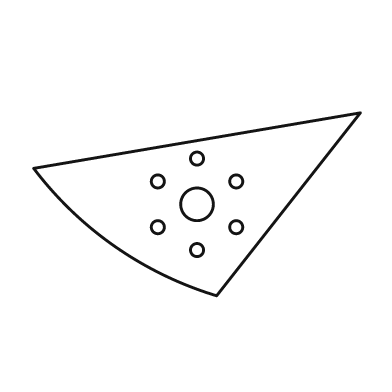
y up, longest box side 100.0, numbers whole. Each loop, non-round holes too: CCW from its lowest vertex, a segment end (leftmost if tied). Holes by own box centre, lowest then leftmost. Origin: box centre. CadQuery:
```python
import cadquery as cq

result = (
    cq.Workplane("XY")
    .moveTo(6.0, -28.0)
    .lineTo(50.0, 28.0)
    .lineTo(-50.0, 11.0)
    .threePointArc((-25.0, -13.0), (6.0, -28.0))
    .close()
    .moveTo(0.0, -14.0)
    .circle(2.0)
    .moveTo(-12.0, -7.0)
    .circle(2.0)
    .moveTo(12.0, -7.0)
    .circle(2.0)
    .moveTo(0.0, 0.0)
    .circle(5.0)
    .moveTo(-12.0, 7.0)
    .circle(2.0)
    .moveTo(12.0, 7.0)
    .circle(2.0)
    .moveTo(0.0, 14.0)
    .circle(2.0)
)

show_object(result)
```